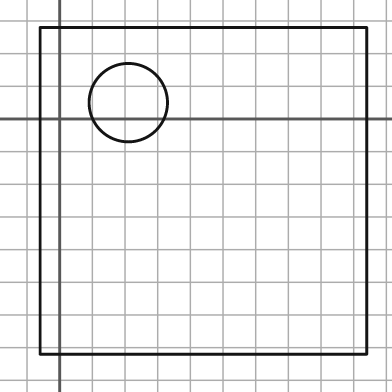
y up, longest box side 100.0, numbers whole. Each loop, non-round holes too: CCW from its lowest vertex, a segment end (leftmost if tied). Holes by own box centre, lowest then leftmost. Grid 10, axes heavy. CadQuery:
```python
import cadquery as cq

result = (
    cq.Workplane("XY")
    .moveTo(-6.0, -72.0)
    .lineTo(94.0, -72.0)
    .lineTo(94.0, 28.0)
    .lineTo(-6.0, 28.0)
    .close()
    .moveTo(21.0, 5.0)
    .circle(12.0)
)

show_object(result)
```